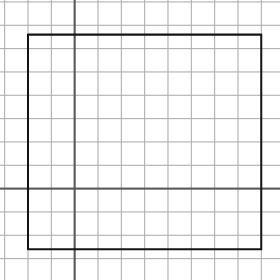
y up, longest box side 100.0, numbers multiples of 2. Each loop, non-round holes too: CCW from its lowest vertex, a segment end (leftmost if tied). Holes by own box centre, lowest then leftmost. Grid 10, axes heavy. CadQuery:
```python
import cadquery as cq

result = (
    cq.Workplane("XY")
    .moveTo(-20.0, -26.0)
    .lineTo(80.0, -26.0)
    .lineTo(80.0, 66.0)
    .lineTo(-20.0, 66.0)
    .close()
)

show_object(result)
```